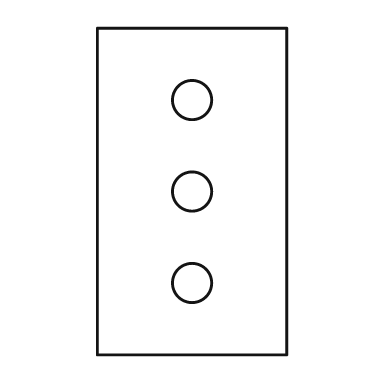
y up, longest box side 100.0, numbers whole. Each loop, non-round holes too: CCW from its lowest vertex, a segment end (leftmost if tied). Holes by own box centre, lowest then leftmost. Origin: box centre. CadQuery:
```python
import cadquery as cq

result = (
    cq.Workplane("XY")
    .moveTo(-29.0, -50.0)
    .lineTo(29.0, -50.0)
    .lineTo(29.0, 50.0)
    .lineTo(-29.0, 50.0)
    .close()
    .moveTo(0.0, -28.0)
    .circle(6.0)
    .moveTo(0.0, 0.0)
    .circle(6.0)
    .moveTo(0.0, 28.0)
    .circle(6.0)
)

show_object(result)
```